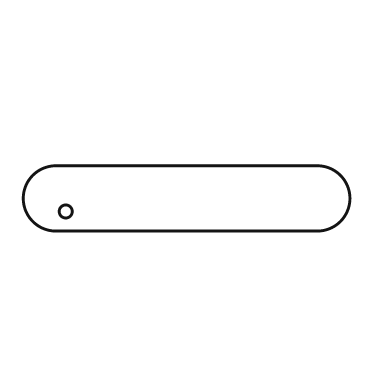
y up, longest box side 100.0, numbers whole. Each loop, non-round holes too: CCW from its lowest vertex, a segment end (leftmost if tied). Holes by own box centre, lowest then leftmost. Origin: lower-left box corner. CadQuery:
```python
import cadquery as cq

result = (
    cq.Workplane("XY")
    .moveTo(10.0, 0.0)
    .lineTo(90.0, 0.0)
    .threePointArc((100.0, 10.0), (90.0, 20.0))
    .lineTo(10.0, 20.0)
    .threePointArc((0.0, 10.0), (10.0, 0.0))
    .close()
    .moveTo(13.0, 6.0)
    .circle(2.0)
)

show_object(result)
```